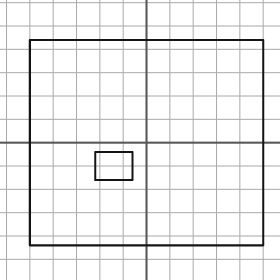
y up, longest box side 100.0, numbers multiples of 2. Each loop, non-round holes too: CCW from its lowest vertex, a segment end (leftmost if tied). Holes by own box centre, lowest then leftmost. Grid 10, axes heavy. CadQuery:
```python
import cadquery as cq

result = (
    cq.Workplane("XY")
    .moveTo(-50.0, -44.0)
    .lineTo(50.0, -44.0)
    .lineTo(50.0, 44.0)
    .lineTo(-50.0, 44.0)
    .close()
    .moveTo(-22.0, -16.0)
    .lineTo(-6.0, -16.0)
    .lineTo(-6.0, -4.0)
    .lineTo(-22.0, -4.0)
    .close()
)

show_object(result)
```